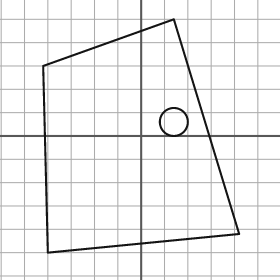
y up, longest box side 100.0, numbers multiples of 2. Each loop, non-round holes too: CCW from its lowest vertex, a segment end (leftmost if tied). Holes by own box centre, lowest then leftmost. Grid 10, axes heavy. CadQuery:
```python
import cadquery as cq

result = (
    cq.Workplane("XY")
    .moveTo(-40.0, -50.0)
    .lineTo(42.0, -42.0)
    .lineTo(14.0, 50.0)
    .lineTo(-42.0, 30.0)
    .close()
    .moveTo(14.0, 6.0)
    .circle(6.0)
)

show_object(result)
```